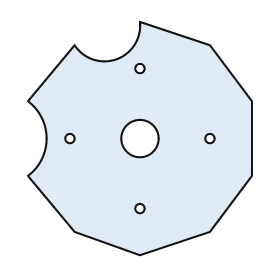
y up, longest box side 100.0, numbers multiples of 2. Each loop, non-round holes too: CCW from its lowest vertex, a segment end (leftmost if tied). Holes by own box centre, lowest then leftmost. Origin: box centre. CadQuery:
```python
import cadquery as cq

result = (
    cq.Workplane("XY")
    .moveTo(0.0, -50.0)
    .lineTo(30.0, -40.0)
    .lineTo(48.0, -16.0)
    .lineTo(48.0, 16.0)
    .lineTo(30.0, 40.0)
    .lineTo(0.0, 50.0)
    .threePointArc((-10.0, 34.0), (-28.0, 40.0))
    .lineTo(-48.0, 16.0)
    .threePointArc((-40.0, 0.0), (-48.0, -16.0))
    .lineTo(-28.0, -40.0)
    .close()
    .moveTo(0.0, -30.0)
    .circle(2.0)
    .moveTo(-30.0, 0.0)
    .circle(2.0)
    .moveTo(0.0, 0.0)
    .circle(8.0)
    .moveTo(30.0, 0.0)
    .circle(2.0)
    .moveTo(0.0, 30.0)
    .circle(2.0)
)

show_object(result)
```